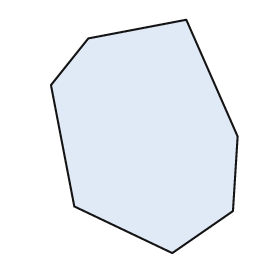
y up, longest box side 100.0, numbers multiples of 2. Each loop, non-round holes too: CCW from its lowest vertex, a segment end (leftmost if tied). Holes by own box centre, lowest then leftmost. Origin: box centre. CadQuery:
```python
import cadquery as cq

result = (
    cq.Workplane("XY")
    .moveTo(12.0, -50.0)
    .lineTo(38.0, -32.0)
    .lineTo(40.0, 0.0)
    .lineTo(18.0, 50.0)
    .lineTo(-24.0, 42.0)
    .lineTo(-40.0, 22.0)
    .lineTo(-30.0, -30.0)
    .close()
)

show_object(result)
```